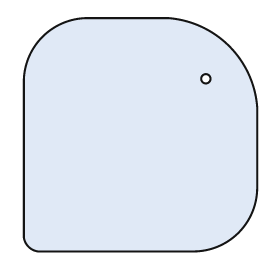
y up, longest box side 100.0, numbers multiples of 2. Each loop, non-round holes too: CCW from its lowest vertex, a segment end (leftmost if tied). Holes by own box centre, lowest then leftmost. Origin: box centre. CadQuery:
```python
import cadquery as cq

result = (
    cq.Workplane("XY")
    .moveTo(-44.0, -50.0)
    .lineTo(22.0, -50.0)
    .threePointArc((42.0, -42.0), (50.0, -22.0))
    .lineTo(50.0, 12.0)
    .threePointArc((38.0, 38.0), (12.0, 50.0))
    .lineTo(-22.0, 50.0)
    .threePointArc((-42.0, 42.0), (-50.0, 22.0))
    .lineTo(-50.0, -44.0)
    .threePointArc((-48.0, -48.0), (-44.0, -50.0))
    .close()
    .moveTo(28.0, 24.0)
    .circle(2.0)
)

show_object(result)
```